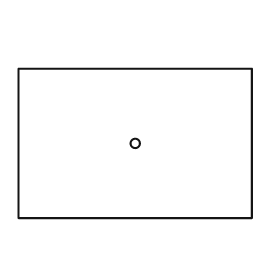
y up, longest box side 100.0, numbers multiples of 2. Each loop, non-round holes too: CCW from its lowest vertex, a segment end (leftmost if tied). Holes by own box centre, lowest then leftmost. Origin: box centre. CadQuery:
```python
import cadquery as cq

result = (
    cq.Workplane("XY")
    .moveTo(-50.0, -32.0)
    .lineTo(50.0, -32.0)
    .lineTo(50.0, 32.0)
    .lineTo(-50.0, 32.0)
    .close()
    .moveTo(0.0, 0.0)
    .circle(2.0)
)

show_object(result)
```